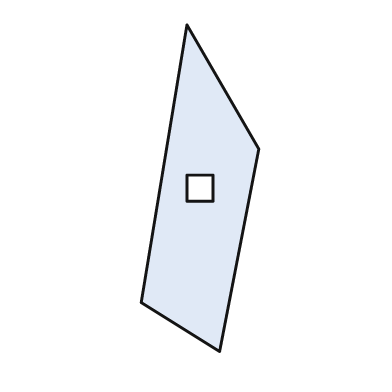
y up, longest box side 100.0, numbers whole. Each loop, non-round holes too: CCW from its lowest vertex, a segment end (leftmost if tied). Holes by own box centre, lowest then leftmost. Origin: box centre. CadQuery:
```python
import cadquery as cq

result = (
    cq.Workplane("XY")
    .moveTo(6.0, -50.0)
    .lineTo(18.0, 12.0)
    .lineTo(-4.0, 50.0)
    .lineTo(-18.0, -35.0)
    .close()
    .moveTo(-4.0, -4.0)
    .lineTo(4.0, -4.0)
    .lineTo(4.0, 4.0)
    .lineTo(-4.0, 4.0)
    .close()
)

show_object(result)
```